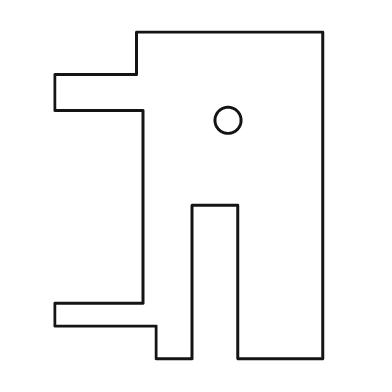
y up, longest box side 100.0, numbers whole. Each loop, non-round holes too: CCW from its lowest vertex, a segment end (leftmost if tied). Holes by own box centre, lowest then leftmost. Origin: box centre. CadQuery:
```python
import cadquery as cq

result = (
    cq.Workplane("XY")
    .moveTo(-10.0, -50.0)
    .lineTo(1.0, -50.0)
    .lineTo(1.0, -3.0)
    .lineTo(15.0, -3.0)
    .lineTo(15.0, -50.0)
    .lineTo(41.0, -50.0)
    .lineTo(41.0, 50.0)
    .lineTo(-16.0, 50.0)
    .lineTo(-16.0, 37.0)
    .lineTo(-41.0, 37.0)
    .lineTo(-41.0, 26.0)
    .lineTo(-14.0, 26.0)
    .lineTo(-14.0, -33.0)
    .lineTo(-41.0, -33.0)
    .lineTo(-41.0, -40.0)
    .lineTo(-10.0, -40.0)
    .close()
    .moveTo(12.0, 23.0)
    .circle(4.0)
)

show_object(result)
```